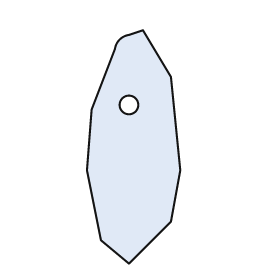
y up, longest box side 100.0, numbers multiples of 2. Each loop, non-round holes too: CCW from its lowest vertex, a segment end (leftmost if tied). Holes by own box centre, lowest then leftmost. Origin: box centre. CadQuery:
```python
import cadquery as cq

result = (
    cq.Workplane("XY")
    .moveTo(-2.0, -50.0)
    .lineTo(16.0, -32.0)
    .lineTo(20.0, -10.0)
    .lineTo(16.0, 30.0)
    .lineTo(4.0, 50.0)
    .lineTo(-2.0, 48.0)
    .threePointArc((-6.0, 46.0), (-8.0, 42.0))
    .lineTo(-18.0, 16.0)
    .lineTo(-20.0, -10.0)
    .lineTo(-14.0, -40.0)
    .close()
    .moveTo(-2.0, 18.0)
    .circle(4.0)
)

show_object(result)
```